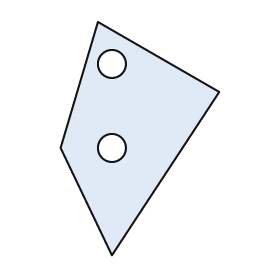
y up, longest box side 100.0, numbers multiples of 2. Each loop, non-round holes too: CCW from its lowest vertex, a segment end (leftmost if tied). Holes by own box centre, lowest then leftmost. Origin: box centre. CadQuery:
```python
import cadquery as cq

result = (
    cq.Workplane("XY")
    .moveTo(-12.0, -50.0)
    .lineTo(34.0, 20.0)
    .lineTo(-18.0, 50.0)
    .lineTo(-34.0, -4.0)
    .close()
    .moveTo(-12.0, -4.0)
    .circle(6.0)
    .moveTo(-12.0, 32.0)
    .circle(6.0)
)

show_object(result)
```